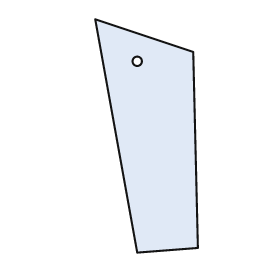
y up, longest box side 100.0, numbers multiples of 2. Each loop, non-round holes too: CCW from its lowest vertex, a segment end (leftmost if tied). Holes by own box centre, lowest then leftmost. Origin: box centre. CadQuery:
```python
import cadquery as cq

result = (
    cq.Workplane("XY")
    .moveTo(-4.0, -50.0)
    .lineTo(22.0, -48.0)
    .lineTo(20.0, 36.0)
    .lineTo(-22.0, 50.0)
    .close()
    .moveTo(-4.0, 32.0)
    .circle(2.0)
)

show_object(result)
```